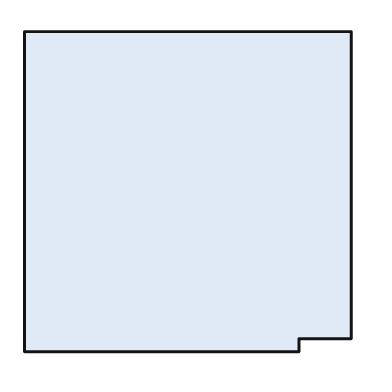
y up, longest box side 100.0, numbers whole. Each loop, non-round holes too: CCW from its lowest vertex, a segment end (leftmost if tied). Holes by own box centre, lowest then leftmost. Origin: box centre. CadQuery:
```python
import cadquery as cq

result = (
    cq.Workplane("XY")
    .moveTo(-50.0, -49.0)
    .lineTo(34.0, -49.0)
    .lineTo(34.0, -45.0)
    .lineTo(50.0, -45.0)
    .lineTo(50.0, 49.0)
    .lineTo(-50.0, 49.0)
    .close()
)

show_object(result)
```